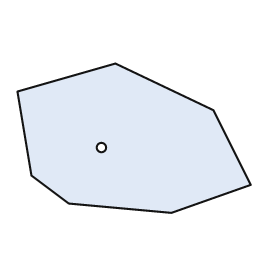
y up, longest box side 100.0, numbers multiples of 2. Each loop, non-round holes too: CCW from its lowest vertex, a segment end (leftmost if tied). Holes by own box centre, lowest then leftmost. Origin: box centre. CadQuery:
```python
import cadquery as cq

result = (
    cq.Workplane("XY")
    .moveTo(16.0, -32.0)
    .lineTo(50.0, -20.0)
    .lineTo(34.0, 12.0)
    .lineTo(-8.0, 32.0)
    .lineTo(-50.0, 20.0)
    .lineTo(-44.0, -16.0)
    .lineTo(-28.0, -28.0)
    .close()
    .moveTo(-14.0, -4.0)
    .circle(2.0)
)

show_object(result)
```